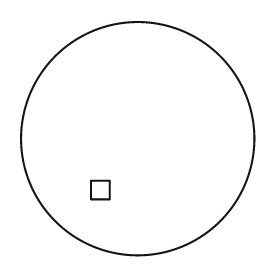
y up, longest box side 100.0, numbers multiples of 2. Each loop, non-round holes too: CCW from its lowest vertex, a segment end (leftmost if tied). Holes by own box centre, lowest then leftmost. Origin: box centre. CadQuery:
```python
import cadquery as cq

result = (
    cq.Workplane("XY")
    .moveTo(0.0, 0.0)
    .circle(50.0)
    .moveTo(-20.0, -26.0)
    .lineTo(-12.0, -26.0)
    .lineTo(-12.0, -18.0)
    .lineTo(-20.0, -18.0)
    .close()
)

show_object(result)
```